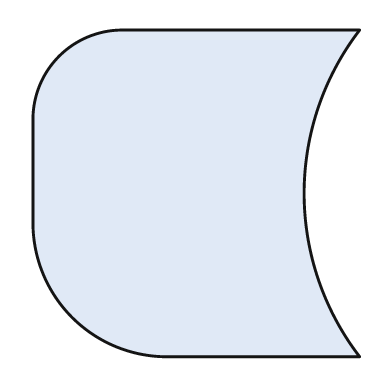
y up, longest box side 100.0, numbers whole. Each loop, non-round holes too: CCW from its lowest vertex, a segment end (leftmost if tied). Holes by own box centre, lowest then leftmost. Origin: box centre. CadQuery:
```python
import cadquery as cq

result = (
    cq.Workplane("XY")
    .moveTo(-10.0, -50.0)
    .lineTo(50.0, -50.0)
    .threePointArc((33.0, 0.0), (50.0, 50.0))
    .lineTo(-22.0, 50.0)
    .threePointArc((-42.0, 42.0), (-50.0, 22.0))
    .lineTo(-50.0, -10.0)
    .threePointArc((-38.0, -38.0), (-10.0, -50.0))
    .close()
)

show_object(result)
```